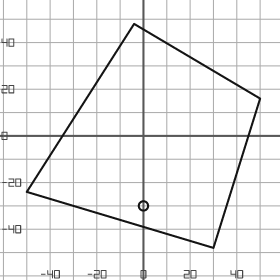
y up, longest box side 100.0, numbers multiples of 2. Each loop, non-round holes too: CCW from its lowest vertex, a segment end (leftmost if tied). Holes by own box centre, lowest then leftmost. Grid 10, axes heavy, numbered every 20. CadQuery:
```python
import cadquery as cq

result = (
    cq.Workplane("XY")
    .moveTo(30.0, -48.0)
    .lineTo(50.0, 16.0)
    .lineTo(-4.0, 48.0)
    .lineTo(-50.0, -24.0)
    .close()
    .moveTo(0.0, -30.0)
    .circle(2.0)
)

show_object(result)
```